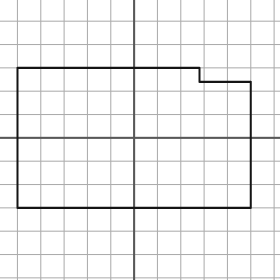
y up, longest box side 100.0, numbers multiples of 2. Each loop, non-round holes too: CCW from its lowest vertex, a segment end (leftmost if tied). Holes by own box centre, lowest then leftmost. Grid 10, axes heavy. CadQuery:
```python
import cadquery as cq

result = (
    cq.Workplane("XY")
    .moveTo(-50.0, -30.0)
    .lineTo(50.0, -30.0)
    .lineTo(50.0, 24.0)
    .lineTo(28.0, 24.0)
    .lineTo(28.0, 30.0)
    .lineTo(-50.0, 30.0)
    .close()
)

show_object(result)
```